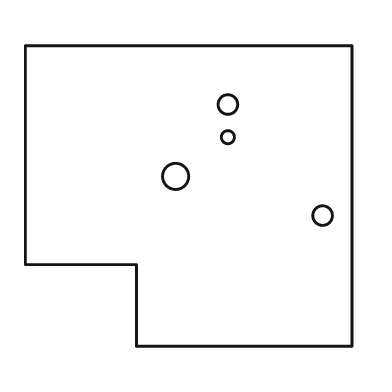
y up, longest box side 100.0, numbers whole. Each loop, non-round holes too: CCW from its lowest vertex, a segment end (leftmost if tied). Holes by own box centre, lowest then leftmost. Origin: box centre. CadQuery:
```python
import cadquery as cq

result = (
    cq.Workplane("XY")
    .moveTo(-16.0, -46.0)
    .lineTo(50.0, -46.0)
    .lineTo(50.0, 46.0)
    .lineTo(-50.0, 46.0)
    .lineTo(-50.0, -21.0)
    .lineTo(-16.0, -21.0)
    .close()
    .moveTo(41.0, -6.0)
    .circle(3.0)
    .moveTo(-4.0, 6.0)
    .circle(4.0)
    .moveTo(12.0, 18.0)
    .circle(2.0)
    .moveTo(12.0, 28.0)
    .circle(3.0)
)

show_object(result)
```